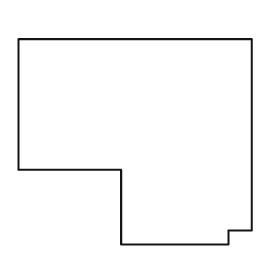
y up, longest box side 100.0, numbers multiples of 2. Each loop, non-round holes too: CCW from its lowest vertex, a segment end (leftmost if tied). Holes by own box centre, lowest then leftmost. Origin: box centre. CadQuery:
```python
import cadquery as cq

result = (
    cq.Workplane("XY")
    .moveTo(-6.0, -44.0)
    .lineTo(40.0, -44.0)
    .lineTo(40.0, -38.0)
    .lineTo(50.0, -38.0)
    .lineTo(50.0, 44.0)
    .lineTo(-50.0, 44.0)
    .lineTo(-50.0, -12.0)
    .lineTo(-6.0, -12.0)
    .close()
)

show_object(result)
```